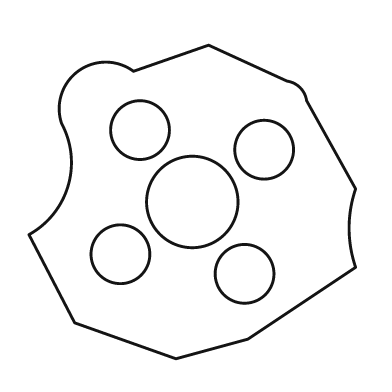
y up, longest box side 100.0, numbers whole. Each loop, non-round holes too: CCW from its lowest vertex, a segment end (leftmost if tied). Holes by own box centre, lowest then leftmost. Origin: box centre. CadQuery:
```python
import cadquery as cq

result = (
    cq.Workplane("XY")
    .moveTo(-5.0, -48.0)
    .lineTo(17.0, -42.0)
    .lineTo(50.0, -20.0)
    .threePointArc((48.0, -8.0), (50.0, 4.0))
    .lineTo(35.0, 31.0)
    .threePointArc((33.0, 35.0), (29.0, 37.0))
    .lineTo(5.0, 48.0)
    .lineTo(-18.0, 40.0)
    .threePointArc((-35.0, 40.0), (-40.0, 24.0))
    .threePointArc((-38.0, 5.0), (-50.0, -10.0))
    .lineTo(-36.0, -37.0)
    .close()
    .moveTo(16.0, -22.0)
    .circle(9.0)
    .moveTo(-22.0, -16.0)
    .circle(9.0)
    .moveTo(0.0, 0.0)
    .circle(14.0)
    .moveTo(22.0, 16.0)
    .circle(9.0)
    .moveTo(-16.0, 22.0)
    .circle(9.0)
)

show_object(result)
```